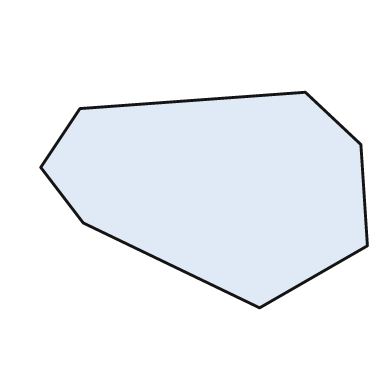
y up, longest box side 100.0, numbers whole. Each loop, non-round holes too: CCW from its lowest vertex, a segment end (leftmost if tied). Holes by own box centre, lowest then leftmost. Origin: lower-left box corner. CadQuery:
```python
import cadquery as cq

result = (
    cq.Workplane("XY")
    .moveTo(67.0, 0.0)
    .lineTo(100.0, 19.0)
    .lineTo(98.0, 50.0)
    .lineTo(81.0, 66.0)
    .lineTo(12.0, 61.0)
    .lineTo(0.0, 43.0)
    .lineTo(13.0, 26.0)
    .close()
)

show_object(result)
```